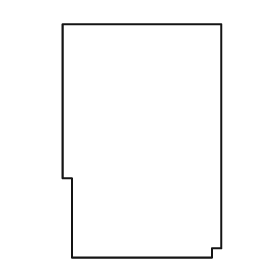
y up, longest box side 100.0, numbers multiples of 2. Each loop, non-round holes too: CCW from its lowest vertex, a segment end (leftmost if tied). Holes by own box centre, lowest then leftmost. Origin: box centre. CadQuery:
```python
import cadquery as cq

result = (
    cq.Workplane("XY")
    .moveTo(-30.0, -50.0)
    .lineTo(30.0, -50.0)
    .lineTo(30.0, -46.0)
    .lineTo(34.0, -46.0)
    .lineTo(34.0, 50.0)
    .lineTo(-34.0, 50.0)
    .lineTo(-34.0, -16.0)
    .lineTo(-30.0, -16.0)
    .close()
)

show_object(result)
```